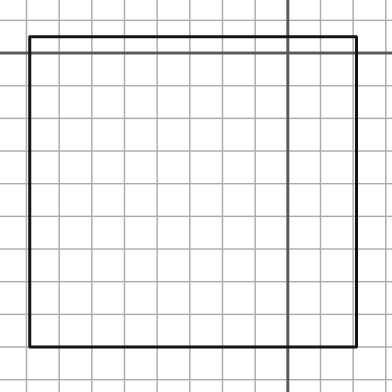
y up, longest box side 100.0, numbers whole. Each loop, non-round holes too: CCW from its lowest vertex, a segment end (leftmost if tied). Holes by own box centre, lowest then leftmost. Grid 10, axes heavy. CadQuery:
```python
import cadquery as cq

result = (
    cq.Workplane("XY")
    .moveTo(-79.0, -90.0)
    .lineTo(21.0, -90.0)
    .lineTo(21.0, 5.0)
    .lineTo(-79.0, 5.0)
    .close()
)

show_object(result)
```